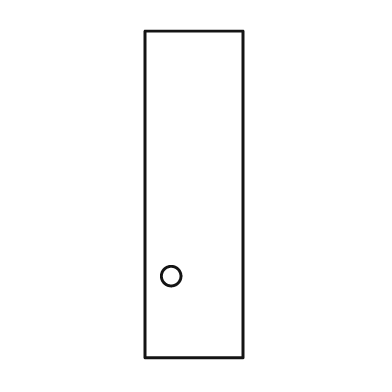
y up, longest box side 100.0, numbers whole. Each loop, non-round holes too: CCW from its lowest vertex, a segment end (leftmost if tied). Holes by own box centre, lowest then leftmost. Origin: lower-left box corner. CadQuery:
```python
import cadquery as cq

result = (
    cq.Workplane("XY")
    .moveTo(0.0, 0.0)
    .lineTo(30.0, 0.0)
    .lineTo(30.0, 100.0)
    .lineTo(0.0, 100.0)
    .close()
    .moveTo(8.0, 25.0)
    .circle(3.0)
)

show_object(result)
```